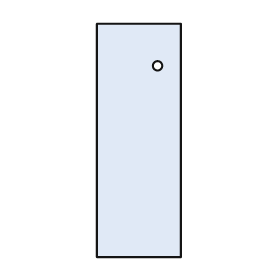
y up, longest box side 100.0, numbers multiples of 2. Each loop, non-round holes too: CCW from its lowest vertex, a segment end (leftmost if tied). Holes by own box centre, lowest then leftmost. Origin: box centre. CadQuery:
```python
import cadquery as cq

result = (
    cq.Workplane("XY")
    .moveTo(-18.0, -50.0)
    .lineTo(18.0, -50.0)
    .lineTo(18.0, 50.0)
    .lineTo(-18.0, 50.0)
    .close()
    .moveTo(8.0, 32.0)
    .circle(2.0)
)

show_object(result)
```